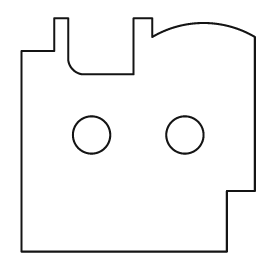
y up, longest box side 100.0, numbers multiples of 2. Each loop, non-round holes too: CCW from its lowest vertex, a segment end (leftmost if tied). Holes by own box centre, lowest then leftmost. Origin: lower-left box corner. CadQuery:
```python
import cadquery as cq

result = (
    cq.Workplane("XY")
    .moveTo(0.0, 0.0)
    .lineTo(88.0, 0.0)
    .lineTo(88.0, 26.0)
    .lineTo(100.0, 26.0)
    .lineTo(100.0, 92.0)
    .threePointArc((78.0, 98.0), (56.0, 92.0))
    .lineTo(56.0, 100.0)
    .lineTo(48.0, 100.0)
    .lineTo(48.0, 76.0)
    .lineTo(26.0, 76.0)
    .threePointArc((22.0, 78.0), (20.0, 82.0))
    .lineTo(20.0, 100.0)
    .lineTo(14.0, 100.0)
    .lineTo(14.0, 86.0)
    .lineTo(0.0, 86.0)
    .close()
    .moveTo(30.0, 50.0)
    .circle(8.0)
    .moveTo(70.0, 50.0)
    .circle(8.0)
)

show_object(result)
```